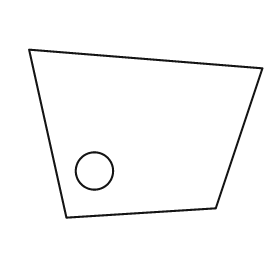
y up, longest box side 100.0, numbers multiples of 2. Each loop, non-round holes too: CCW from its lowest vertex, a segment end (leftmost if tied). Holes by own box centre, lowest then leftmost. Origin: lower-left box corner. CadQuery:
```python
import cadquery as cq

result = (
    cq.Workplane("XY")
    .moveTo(16.0, 0.0)
    .lineTo(80.0, 4.0)
    .lineTo(100.0, 64.0)
    .lineTo(0.0, 72.0)
    .close()
    .moveTo(28.0, 20.0)
    .circle(8.0)
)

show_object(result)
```